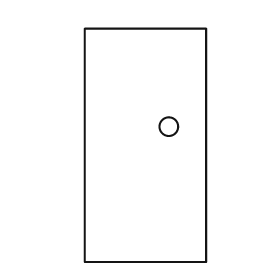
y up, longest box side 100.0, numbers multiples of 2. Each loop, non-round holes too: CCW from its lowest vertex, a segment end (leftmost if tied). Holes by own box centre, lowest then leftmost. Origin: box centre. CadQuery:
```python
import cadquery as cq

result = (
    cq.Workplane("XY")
    .moveTo(-26.0, -50.0)
    .lineTo(26.0, -50.0)
    .lineTo(26.0, 50.0)
    .lineTo(-26.0, 50.0)
    .close()
    .moveTo(10.0, 8.0)
    .circle(4.0)
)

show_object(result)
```